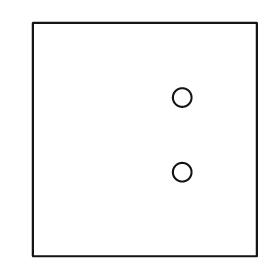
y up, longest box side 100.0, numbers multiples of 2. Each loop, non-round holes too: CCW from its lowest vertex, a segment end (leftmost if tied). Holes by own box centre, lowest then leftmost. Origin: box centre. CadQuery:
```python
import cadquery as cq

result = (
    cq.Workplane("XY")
    .moveTo(-48.0, -50.0)
    .lineTo(48.0, -50.0)
    .lineTo(48.0, 50.0)
    .lineTo(-48.0, 50.0)
    .close()
    .moveTo(16.0, -14.0)
    .circle(4.0)
    .moveTo(16.0, 18.0)
    .circle(4.0)
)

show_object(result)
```